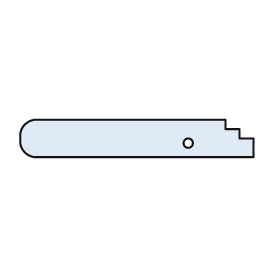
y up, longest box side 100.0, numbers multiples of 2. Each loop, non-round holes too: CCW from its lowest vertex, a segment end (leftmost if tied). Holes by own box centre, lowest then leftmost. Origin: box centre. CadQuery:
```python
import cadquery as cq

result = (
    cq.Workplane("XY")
    .moveTo(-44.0, -8.0)
    .lineTo(50.0, -8.0)
    .lineTo(50.0, 0.0)
    .lineTo(44.0, 0.0)
    .lineTo(44.0, 4.0)
    .lineTo(38.0, 4.0)
    .lineTo(38.0, 8.0)
    .lineTo(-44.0, 8.0)
    .threePointArc((-48.0, 6.0), (-50.0, 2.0))
    .lineTo(-50.0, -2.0)
    .threePointArc((-48.0, -6.0), (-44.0, -8.0))
    .close()
    .moveTo(22.0, -2.0)
    .circle(2.0)
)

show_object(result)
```